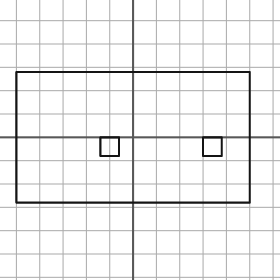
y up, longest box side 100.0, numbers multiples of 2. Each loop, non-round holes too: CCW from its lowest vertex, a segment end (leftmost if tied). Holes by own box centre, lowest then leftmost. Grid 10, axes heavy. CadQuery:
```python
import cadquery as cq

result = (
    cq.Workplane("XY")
    .moveTo(-50.0, -28.0)
    .lineTo(50.0, -28.0)
    .lineTo(50.0, 28.0)
    .lineTo(-50.0, 28.0)
    .close()
    .moveTo(-14.0, -8.0)
    .lineTo(-6.0, -8.0)
    .lineTo(-6.0, 0.0)
    .lineTo(-14.0, 0.0)
    .close()
    .moveTo(30.0, -8.0)
    .lineTo(38.0, -8.0)
    .lineTo(38.0, 0.0)
    .lineTo(30.0, 0.0)
    .close()
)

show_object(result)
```